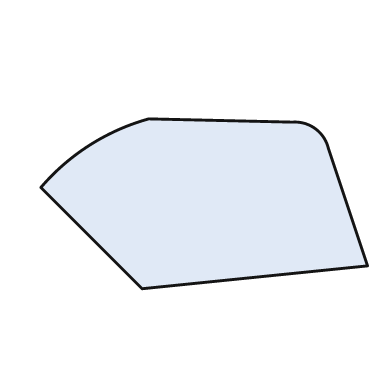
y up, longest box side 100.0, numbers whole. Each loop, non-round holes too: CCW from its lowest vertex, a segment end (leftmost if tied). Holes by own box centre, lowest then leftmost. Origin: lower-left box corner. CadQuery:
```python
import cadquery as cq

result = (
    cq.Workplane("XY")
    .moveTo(31.0, 0.0)
    .lineTo(100.0, 7.0)
    .lineTo(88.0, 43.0)
    .threePointArc((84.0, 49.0), (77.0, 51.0))
    .lineTo(33.0, 52.0)
    .threePointArc((15.0, 44.0), (0.0, 31.0))
    .close()
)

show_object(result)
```